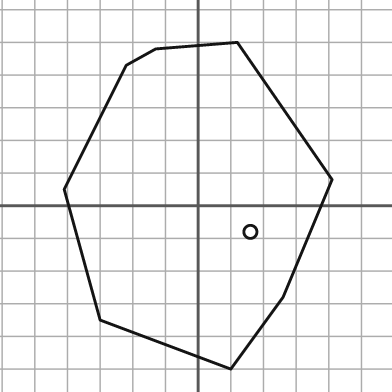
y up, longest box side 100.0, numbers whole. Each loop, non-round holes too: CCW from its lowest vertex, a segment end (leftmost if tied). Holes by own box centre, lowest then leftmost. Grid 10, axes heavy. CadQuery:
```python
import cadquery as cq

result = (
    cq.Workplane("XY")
    .moveTo(10.0, -50.0)
    .lineTo(26.0, -28.0)
    .lineTo(41.0, 8.0)
    .lineTo(12.0, 50.0)
    .lineTo(-13.0, 48.0)
    .lineTo(-22.0, 43.0)
    .lineTo(-41.0, 5.0)
    .lineTo(-30.0, -35.0)
    .close()
    .moveTo(16.0, -8.0)
    .circle(2.0)
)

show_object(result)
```